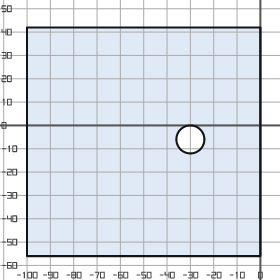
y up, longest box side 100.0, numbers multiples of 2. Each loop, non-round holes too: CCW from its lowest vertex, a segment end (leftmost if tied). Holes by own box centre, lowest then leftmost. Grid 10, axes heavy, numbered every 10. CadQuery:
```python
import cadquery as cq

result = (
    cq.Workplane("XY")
    .moveTo(-100.0, -56.0)
    .lineTo(0.0, -56.0)
    .lineTo(0.0, 42.0)
    .lineTo(-100.0, 42.0)
    .close()
    .moveTo(-30.0, -6.0)
    .circle(6.0)
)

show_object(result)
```